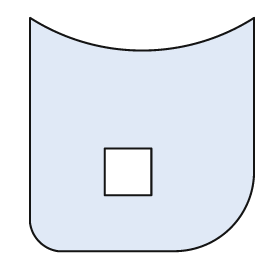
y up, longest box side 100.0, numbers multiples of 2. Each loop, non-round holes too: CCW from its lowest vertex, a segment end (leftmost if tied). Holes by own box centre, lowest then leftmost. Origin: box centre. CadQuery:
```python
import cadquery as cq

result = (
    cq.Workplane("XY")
    .moveTo(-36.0, -50.0)
    .lineTo(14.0, -50.0)
    .threePointArc((38.0, -40.0), (48.0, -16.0))
    .lineTo(48.0, 50.0)
    .threePointArc((0.0, 36.0), (-48.0, 50.0))
    .lineTo(-48.0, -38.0)
    .threePointArc((-44.0, -46.0), (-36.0, -50.0))
    .close()
    .moveTo(-16.0, -26.0)
    .lineTo(4.0, -26.0)
    .lineTo(4.0, -6.0)
    .lineTo(-16.0, -6.0)
    .close()
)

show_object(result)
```